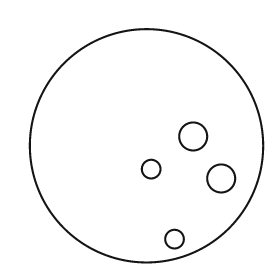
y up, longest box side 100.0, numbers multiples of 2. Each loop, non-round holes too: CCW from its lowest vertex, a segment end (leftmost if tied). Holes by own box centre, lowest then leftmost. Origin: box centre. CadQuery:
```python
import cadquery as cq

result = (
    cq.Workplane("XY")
    .moveTo(0.0, 0.0)
    .circle(50.0)
    .moveTo(12.0, -40.0)
    .circle(4.0)
    .moveTo(32.0, -14.0)
    .circle(6.0)
    .moveTo(2.0, -10.0)
    .circle(4.0)
    .moveTo(20.0, 4.0)
    .circle(6.0)
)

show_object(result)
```